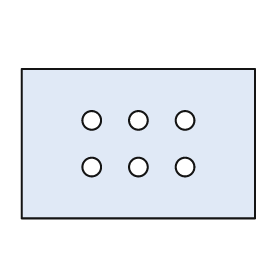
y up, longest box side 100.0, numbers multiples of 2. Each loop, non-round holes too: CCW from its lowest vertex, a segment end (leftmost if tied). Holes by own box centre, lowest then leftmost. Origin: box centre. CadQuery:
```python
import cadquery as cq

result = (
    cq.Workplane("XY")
    .moveTo(-50.0, -32.0)
    .lineTo(50.0, -32.0)
    .lineTo(50.0, 32.0)
    .lineTo(-50.0, 32.0)
    .close()
    .moveTo(-20.0, -10.0)
    .circle(4.0)
    .moveTo(0.0, -10.0)
    .circle(4.0)
    .moveTo(20.0, -10.0)
    .circle(4.0)
    .moveTo(-20.0, 10.0)
    .circle(4.0)
    .moveTo(0.0, 10.0)
    .circle(4.0)
    .moveTo(20.0, 10.0)
    .circle(4.0)
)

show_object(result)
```